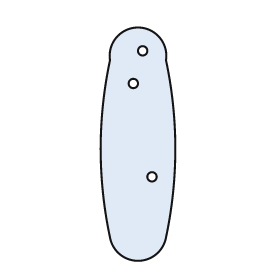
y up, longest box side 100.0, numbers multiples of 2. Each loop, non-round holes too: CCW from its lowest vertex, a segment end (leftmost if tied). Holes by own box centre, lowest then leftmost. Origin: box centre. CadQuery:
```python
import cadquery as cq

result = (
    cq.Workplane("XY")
    .moveTo(-12.0, -40.0)
    .threePointArc((0.0, -50.0), (12.0, -40.0))
    .threePointArc((16.0, -2.0), (12.0, 36.0))
    .threePointArc((0.0, 50.0), (-12.0, 36.0))
    .threePointArc((-16.0, -2.0), (-12.0, -40.0))
    .close()
    .moveTo(6.0, -14.0)
    .circle(2.0)
    .moveTo(-2.0, 26.0)
    .circle(2.0)
    .moveTo(2.0, 40.0)
    .circle(2.0)
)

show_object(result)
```